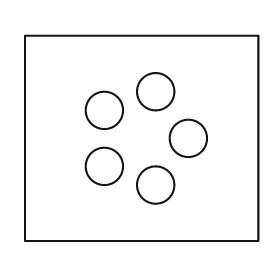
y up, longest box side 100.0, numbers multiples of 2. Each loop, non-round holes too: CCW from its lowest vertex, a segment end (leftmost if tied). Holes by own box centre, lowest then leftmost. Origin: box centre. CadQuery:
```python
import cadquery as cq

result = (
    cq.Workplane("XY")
    .moveTo(-50.0, -44.0)
    .lineTo(50.0, -44.0)
    .lineTo(50.0, 44.0)
    .lineTo(-50.0, 44.0)
    .close()
    .moveTo(6.0, -20.0)
    .circle(8.0)
    .moveTo(-16.0, -12.0)
    .circle(8.0)
    .moveTo(20.0, 0.0)
    .circle(8.0)
    .moveTo(-16.0, 12.0)
    .circle(8.0)
    .moveTo(6.0, 20.0)
    .circle(8.0)
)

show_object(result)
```